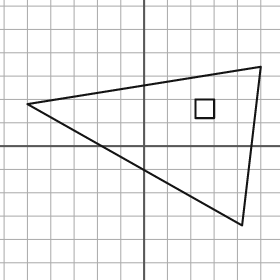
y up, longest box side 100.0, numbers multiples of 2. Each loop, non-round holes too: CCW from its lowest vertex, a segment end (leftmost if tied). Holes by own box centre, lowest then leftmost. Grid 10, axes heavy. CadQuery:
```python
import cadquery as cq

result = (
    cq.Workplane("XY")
    .moveTo(42.0, -34.0)
    .lineTo(50.0, 34.0)
    .lineTo(-50.0, 18.0)
    .close()
    .moveTo(22.0, 12.0)
    .lineTo(30.0, 12.0)
    .lineTo(30.0, 20.0)
    .lineTo(22.0, 20.0)
    .close()
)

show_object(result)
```